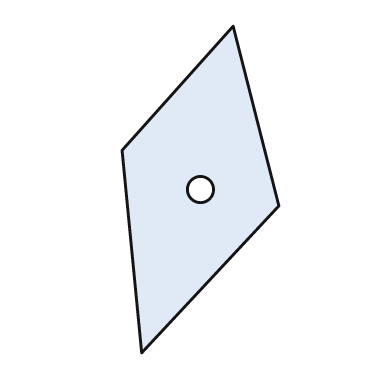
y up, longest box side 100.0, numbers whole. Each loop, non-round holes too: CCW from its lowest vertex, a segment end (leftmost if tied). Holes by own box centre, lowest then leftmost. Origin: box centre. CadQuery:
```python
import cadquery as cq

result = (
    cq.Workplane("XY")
    .moveTo(-18.0, -50.0)
    .lineTo(24.0, -5.0)
    .lineTo(10.0, 50.0)
    .lineTo(-24.0, 12.0)
    .close()
    .moveTo(0.0, 0.0)
    .circle(4.0)
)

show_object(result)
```